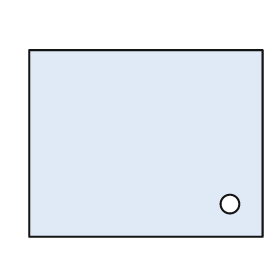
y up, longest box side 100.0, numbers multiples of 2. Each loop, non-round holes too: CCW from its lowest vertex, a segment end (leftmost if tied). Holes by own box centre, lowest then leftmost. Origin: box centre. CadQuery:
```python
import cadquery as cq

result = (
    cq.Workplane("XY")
    .moveTo(-50.0, -40.0)
    .lineTo(50.0, -40.0)
    .lineTo(50.0, 40.0)
    .lineTo(-50.0, 40.0)
    .close()
    .moveTo(36.0, -26.0)
    .circle(4.0)
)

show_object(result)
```